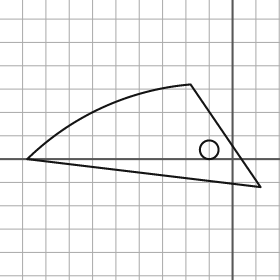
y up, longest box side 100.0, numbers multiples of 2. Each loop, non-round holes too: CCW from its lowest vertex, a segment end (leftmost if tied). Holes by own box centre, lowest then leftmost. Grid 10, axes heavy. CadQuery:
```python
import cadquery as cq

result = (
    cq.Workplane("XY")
    .moveTo(12.0, -12.0)
    .lineTo(-18.0, 32.0)
    .threePointArc((-56.0, 22.0), (-88.0, 0.0))
    .close()
    .moveTo(-10.0, 4.0)
    .circle(4.0)
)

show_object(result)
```